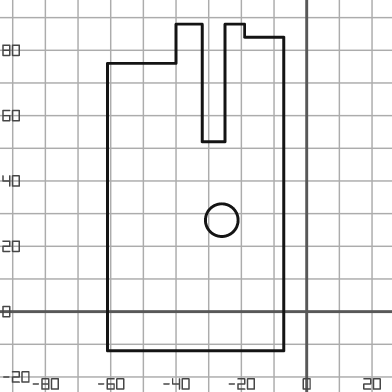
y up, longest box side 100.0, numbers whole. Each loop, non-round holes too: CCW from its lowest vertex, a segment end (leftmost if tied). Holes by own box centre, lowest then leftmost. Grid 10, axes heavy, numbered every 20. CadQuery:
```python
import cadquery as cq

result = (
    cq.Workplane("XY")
    .moveTo(-61.0, -12.0)
    .lineTo(-7.0, -12.0)
    .lineTo(-7.0, 84.0)
    .lineTo(-19.0, 84.0)
    .lineTo(-19.0, 88.0)
    .lineTo(-25.0, 88.0)
    .lineTo(-25.0, 52.0)
    .lineTo(-32.0, 52.0)
    .lineTo(-32.0, 88.0)
    .lineTo(-40.0, 88.0)
    .lineTo(-40.0, 76.0)
    .lineTo(-61.0, 76.0)
    .close()
    .moveTo(-26.0, 28.0)
    .circle(5.0)
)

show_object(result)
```